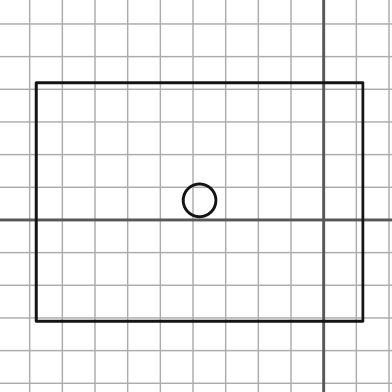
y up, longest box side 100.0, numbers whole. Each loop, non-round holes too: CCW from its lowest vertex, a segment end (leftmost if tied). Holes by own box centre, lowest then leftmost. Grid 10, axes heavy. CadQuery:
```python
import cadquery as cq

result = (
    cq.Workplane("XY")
    .moveTo(-88.0, -31.0)
    .lineTo(12.0, -31.0)
    .lineTo(12.0, 42.0)
    .lineTo(-88.0, 42.0)
    .close()
    .moveTo(-38.0, 6.0)
    .circle(5.0)
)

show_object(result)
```